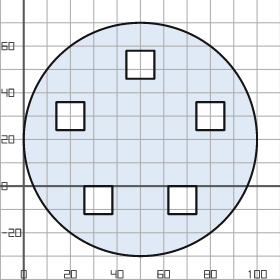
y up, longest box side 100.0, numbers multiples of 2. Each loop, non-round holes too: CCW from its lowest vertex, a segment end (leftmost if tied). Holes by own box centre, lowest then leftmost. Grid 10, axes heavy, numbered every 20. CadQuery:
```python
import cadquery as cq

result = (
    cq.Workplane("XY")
    .moveTo(50.0, 20.0)
    .circle(50.0)
    .moveTo(26.0, -12.0)
    .lineTo(38.0, -12.0)
    .lineTo(38.0, 0.0)
    .lineTo(26.0, 0.0)
    .close()
    .moveTo(62.0, -12.0)
    .lineTo(74.0, -12.0)
    .lineTo(74.0, 0.0)
    .lineTo(62.0, 0.0)
    .close()
    .moveTo(14.0, 24.0)
    .lineTo(26.0, 24.0)
    .lineTo(26.0, 36.0)
    .lineTo(14.0, 36.0)
    .close()
    .moveTo(74.0, 24.0)
    .lineTo(86.0, 24.0)
    .lineTo(86.0, 36.0)
    .lineTo(74.0, 36.0)
    .close()
    .moveTo(44.0, 46.0)
    .lineTo(56.0, 46.0)
    .lineTo(56.0, 58.0)
    .lineTo(44.0, 58.0)
    .close()
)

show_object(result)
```